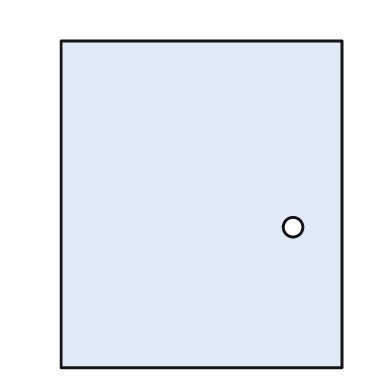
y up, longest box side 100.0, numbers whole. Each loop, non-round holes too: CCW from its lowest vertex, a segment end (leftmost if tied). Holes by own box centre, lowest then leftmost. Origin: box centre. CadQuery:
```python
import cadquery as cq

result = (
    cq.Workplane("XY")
    .moveTo(-43.0, -50.0)
    .lineTo(43.0, -50.0)
    .lineTo(43.0, 50.0)
    .lineTo(-43.0, 50.0)
    .close()
    .moveTo(28.0, -7.0)
    .circle(3.0)
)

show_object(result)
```